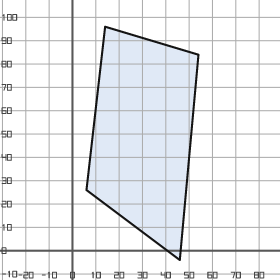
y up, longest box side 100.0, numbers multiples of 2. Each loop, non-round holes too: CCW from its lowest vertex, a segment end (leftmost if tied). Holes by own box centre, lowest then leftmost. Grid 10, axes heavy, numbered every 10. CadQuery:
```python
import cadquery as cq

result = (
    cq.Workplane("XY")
    .moveTo(46.0, -4.0)
    .lineTo(54.0, 84.0)
    .lineTo(14.0, 96.0)
    .lineTo(6.0, 26.0)
    .close()
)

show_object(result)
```